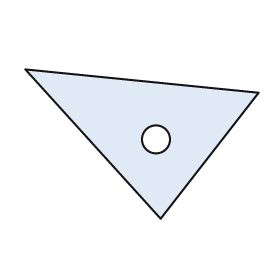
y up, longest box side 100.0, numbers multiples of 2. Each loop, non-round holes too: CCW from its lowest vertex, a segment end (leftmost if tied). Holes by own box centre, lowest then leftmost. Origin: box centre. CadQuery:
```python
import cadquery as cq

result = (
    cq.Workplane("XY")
    .moveTo(8.0, -32.0)
    .lineTo(50.0, 22.0)
    .lineTo(-50.0, 32.0)
    .close()
    .moveTo(6.0, 2.0)
    .circle(6.0)
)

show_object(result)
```